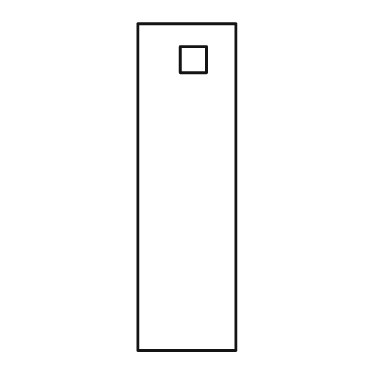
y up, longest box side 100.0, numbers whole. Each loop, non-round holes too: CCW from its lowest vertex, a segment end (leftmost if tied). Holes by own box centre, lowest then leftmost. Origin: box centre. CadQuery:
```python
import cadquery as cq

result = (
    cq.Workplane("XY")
    .moveTo(-15.0, -50.0)
    .lineTo(15.0, -50.0)
    .lineTo(15.0, 50.0)
    .lineTo(-15.0, 50.0)
    .close()
    .moveTo(-2.0, 35.0)
    .lineTo(6.0, 35.0)
    .lineTo(6.0, 43.0)
    .lineTo(-2.0, 43.0)
    .close()
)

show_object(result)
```